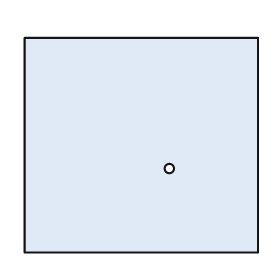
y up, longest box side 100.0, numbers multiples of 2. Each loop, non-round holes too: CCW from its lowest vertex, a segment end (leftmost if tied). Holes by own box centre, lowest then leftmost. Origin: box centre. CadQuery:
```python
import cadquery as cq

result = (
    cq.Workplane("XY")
    .moveTo(-50.0, -46.0)
    .lineTo(50.0, -46.0)
    .lineTo(50.0, 46.0)
    .lineTo(-50.0, 46.0)
    .close()
    .moveTo(12.0, -10.0)
    .circle(2.0)
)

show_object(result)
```